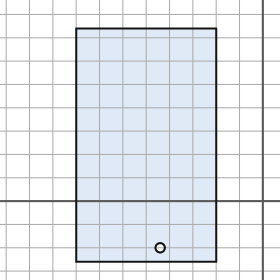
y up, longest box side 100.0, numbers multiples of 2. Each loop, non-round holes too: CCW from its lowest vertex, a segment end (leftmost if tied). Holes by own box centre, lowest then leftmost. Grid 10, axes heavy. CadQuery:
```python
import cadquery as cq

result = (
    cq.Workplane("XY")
    .moveTo(-80.0, -26.0)
    .lineTo(-20.0, -26.0)
    .lineTo(-20.0, 74.0)
    .lineTo(-80.0, 74.0)
    .close()
    .moveTo(-44.0, -20.0)
    .circle(2.0)
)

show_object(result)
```